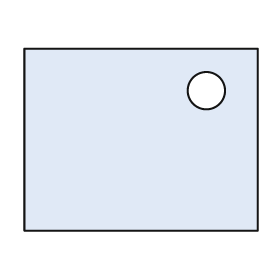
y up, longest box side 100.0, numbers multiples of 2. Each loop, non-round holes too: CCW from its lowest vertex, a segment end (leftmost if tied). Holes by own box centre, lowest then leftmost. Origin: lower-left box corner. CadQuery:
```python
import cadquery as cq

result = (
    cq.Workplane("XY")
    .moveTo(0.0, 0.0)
    .lineTo(100.0, 0.0)
    .lineTo(100.0, 78.0)
    .lineTo(0.0, 78.0)
    .close()
    .moveTo(78.0, 60.0)
    .circle(8.0)
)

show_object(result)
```